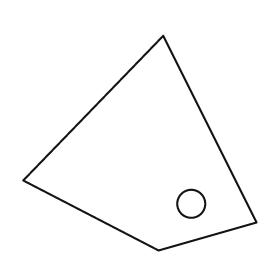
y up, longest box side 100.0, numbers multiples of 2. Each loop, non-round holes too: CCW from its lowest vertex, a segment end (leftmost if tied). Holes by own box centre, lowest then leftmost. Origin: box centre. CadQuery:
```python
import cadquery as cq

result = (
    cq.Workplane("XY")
    .moveTo(8.0, -46.0)
    .lineTo(50.0, -34.0)
    .lineTo(10.0, 46.0)
    .lineTo(-50.0, -16.0)
    .close()
    .moveTo(22.0, -26.0)
    .circle(6.0)
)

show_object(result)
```